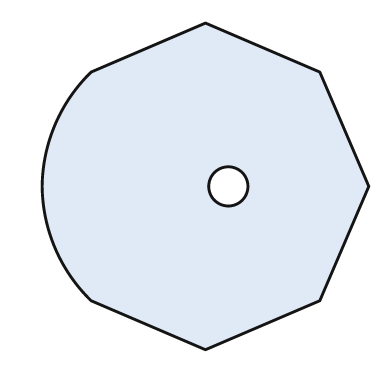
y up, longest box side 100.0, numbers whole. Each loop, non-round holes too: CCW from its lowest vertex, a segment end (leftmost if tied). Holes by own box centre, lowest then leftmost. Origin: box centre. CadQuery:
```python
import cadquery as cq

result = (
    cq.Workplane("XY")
    .moveTo(0.0, -50.0)
    .lineTo(35.0, -35.0)
    .lineTo(50.0, 0.0)
    .lineTo(35.0, 35.0)
    .lineTo(0.0, 50.0)
    .lineTo(-35.0, 35.0)
    .threePointArc((-46.0, 19.0), (-50.0, 0.0))
    .threePointArc((-46.0, -19.0), (-35.0, -35.0))
    .close()
    .moveTo(7.0, 0.0)
    .circle(6.0)
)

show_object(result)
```